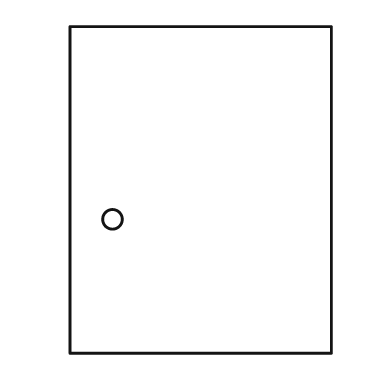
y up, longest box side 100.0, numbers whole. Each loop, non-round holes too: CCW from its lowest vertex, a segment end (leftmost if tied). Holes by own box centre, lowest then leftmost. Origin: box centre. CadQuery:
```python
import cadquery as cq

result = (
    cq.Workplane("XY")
    .moveTo(-40.0, -50.0)
    .lineTo(40.0, -50.0)
    .lineTo(40.0, 50.0)
    .lineTo(-40.0, 50.0)
    .close()
    .moveTo(-27.0, -9.0)
    .circle(3.0)
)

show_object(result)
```